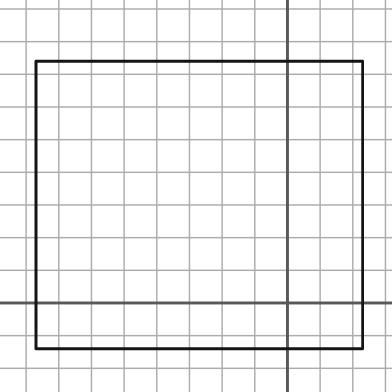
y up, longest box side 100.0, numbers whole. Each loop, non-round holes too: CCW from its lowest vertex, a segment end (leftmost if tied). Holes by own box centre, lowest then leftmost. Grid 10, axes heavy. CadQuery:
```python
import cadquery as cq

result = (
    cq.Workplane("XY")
    .moveTo(-77.0, -14.0)
    .lineTo(23.0, -14.0)
    .lineTo(23.0, 74.0)
    .lineTo(-77.0, 74.0)
    .close()
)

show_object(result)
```